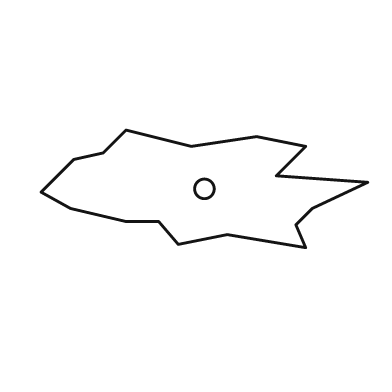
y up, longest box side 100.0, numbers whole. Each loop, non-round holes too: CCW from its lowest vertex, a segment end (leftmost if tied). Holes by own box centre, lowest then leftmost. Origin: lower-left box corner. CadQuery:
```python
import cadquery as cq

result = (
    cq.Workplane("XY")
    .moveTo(81.0, 0.0)
    .lineTo(78.0, 7.0)
    .lineTo(83.0, 12.0)
    .lineTo(100.0, 20.0)
    .lineTo(72.0, 22.0)
    .lineTo(81.0, 31.0)
    .lineTo(66.0, 34.0)
    .lineTo(46.0, 31.0)
    .lineTo(26.0, 36.0)
    .lineTo(19.0, 29.0)
    .lineTo(10.0, 27.0)
    .lineTo(0.0, 17.0)
    .lineTo(9.0, 12.0)
    .lineTo(26.0, 8.0)
    .lineTo(36.0, 8.0)
    .lineTo(42.0, 1.0)
    .lineTo(57.0, 4.0)
    .close()
    .moveTo(50.0, 18.0)
    .circle(3.0)
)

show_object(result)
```